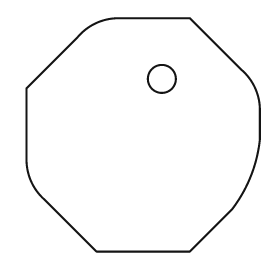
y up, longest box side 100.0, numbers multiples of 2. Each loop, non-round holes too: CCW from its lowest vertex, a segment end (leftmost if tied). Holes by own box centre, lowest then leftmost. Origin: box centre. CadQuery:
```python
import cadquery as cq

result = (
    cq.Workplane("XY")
    .moveTo(-20.0, -50.0)
    .lineTo(20.0, -50.0)
    .lineTo(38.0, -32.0)
    .threePointArc((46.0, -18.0), (50.0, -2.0))
    .lineTo(50.0, 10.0)
    .threePointArc((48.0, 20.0), (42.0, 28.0))
    .lineTo(20.0, 50.0)
    .lineTo(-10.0, 50.0)
    .threePointArc((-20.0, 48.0), (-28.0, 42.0))
    .lineTo(-50.0, 20.0)
    .lineTo(-50.0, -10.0)
    .threePointArc((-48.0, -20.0), (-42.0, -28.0))
    .close()
    .moveTo(8.0, 24.0)
    .circle(6.0)
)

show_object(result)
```